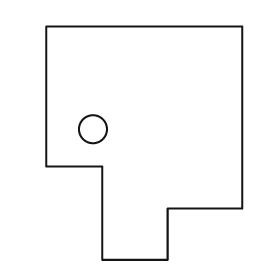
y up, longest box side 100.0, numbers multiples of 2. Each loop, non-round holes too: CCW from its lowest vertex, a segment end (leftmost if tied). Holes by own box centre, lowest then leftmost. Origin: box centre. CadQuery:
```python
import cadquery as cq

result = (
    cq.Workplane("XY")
    .moveTo(-18.0, -50.0)
    .lineTo(10.0, -50.0)
    .lineTo(10.0, -28.0)
    .lineTo(42.0, -28.0)
    .lineTo(42.0, 50.0)
    .lineTo(-42.0, 50.0)
    .lineTo(-42.0, -10.0)
    .lineTo(-18.0, -10.0)
    .close()
    .moveTo(-22.0, 6.0)
    .circle(6.0)
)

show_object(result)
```